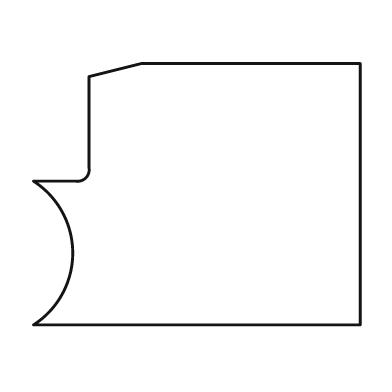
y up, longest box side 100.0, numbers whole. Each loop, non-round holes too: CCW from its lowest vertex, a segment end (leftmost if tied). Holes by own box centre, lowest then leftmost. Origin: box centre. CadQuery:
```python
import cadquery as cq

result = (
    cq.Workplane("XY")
    .moveTo(-50.0, -40.0)
    .lineTo(50.0, -40.0)
    .lineTo(50.0, 40.0)
    .lineTo(-17.0, 40.0)
    .lineTo(-33.0, 36.0)
    .lineTo(-33.0, 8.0)
    .threePointArc((-34.0, 5.0), (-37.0, 4.0))
    .lineTo(-50.0, 4.0)
    .threePointArc((-38.0, -18.0), (-50.0, -40.0))
    .close()
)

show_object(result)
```